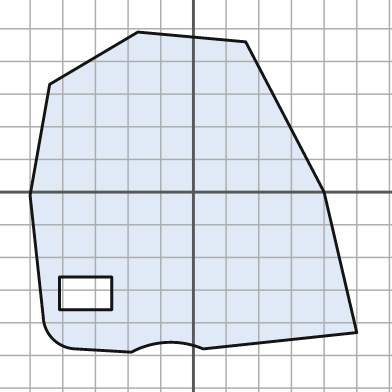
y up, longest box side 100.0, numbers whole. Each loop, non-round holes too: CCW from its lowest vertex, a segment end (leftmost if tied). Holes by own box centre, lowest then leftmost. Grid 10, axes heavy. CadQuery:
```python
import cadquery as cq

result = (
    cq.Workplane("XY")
    .moveTo(-19.0, -49.0)
    .threePointArc((-8.0, -46.0), (3.0, -48.0))
    .lineTo(50.0, -43.0)
    .lineTo(40.0, 0.0)
    .lineTo(16.0, 46.0)
    .lineTo(-17.0, 49.0)
    .lineTo(-44.0, 33.0)
    .lineTo(-50.0, -1.0)
    .lineTo(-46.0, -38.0)
    .threePointArc((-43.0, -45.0), (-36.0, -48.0))
    .close()
    .moveTo(-41.0, -36.0)
    .lineTo(-25.0, -36.0)
    .lineTo(-25.0, -26.0)
    .lineTo(-41.0, -26.0)
    .close()
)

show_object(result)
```